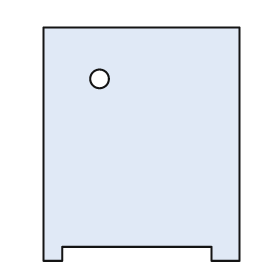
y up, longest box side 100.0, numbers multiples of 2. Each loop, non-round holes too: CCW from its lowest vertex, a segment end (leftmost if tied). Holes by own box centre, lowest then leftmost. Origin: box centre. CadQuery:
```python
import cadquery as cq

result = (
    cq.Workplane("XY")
    .moveTo(-42.0, -50.0)
    .lineTo(-34.0, -50.0)
    .lineTo(-34.0, -44.0)
    .lineTo(30.0, -44.0)
    .lineTo(30.0, -50.0)
    .lineTo(42.0, -50.0)
    .lineTo(42.0, 50.0)
    .lineTo(-42.0, 50.0)
    .close()
    .moveTo(-18.0, 28.0)
    .circle(4.0)
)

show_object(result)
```